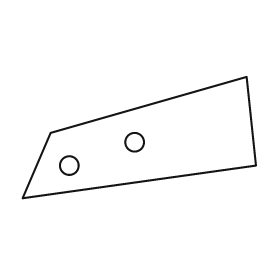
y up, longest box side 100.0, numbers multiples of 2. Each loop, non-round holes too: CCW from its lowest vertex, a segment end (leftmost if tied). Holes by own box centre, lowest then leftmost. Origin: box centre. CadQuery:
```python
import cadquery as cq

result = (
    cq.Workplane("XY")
    .moveTo(-50.0, -26.0)
    .lineTo(50.0, -12.0)
    .lineTo(46.0, 26.0)
    .lineTo(-38.0, 2.0)
    .close()
    .moveTo(-30.0, -12.0)
    .circle(4.0)
    .moveTo(-2.0, -2.0)
    .circle(4.0)
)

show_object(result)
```